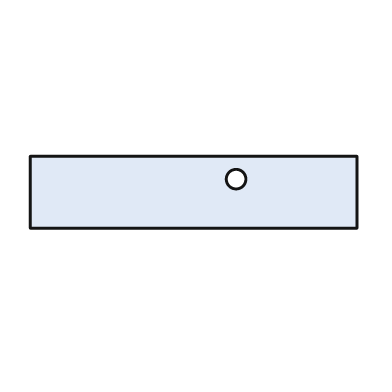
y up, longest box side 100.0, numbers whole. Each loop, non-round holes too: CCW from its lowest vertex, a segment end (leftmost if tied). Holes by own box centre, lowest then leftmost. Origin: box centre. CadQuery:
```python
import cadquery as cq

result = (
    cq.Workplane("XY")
    .moveTo(-50.0, -11.0)
    .lineTo(50.0, -11.0)
    .lineTo(50.0, 11.0)
    .lineTo(-50.0, 11.0)
    .close()
    .moveTo(13.0, 4.0)
    .circle(3.0)
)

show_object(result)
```